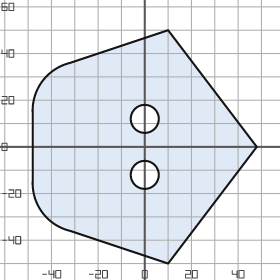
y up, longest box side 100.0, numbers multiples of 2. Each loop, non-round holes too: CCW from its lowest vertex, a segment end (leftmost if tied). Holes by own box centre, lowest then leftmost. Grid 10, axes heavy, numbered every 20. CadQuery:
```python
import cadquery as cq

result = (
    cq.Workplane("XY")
    .moveTo(10.0, -50.0)
    .lineTo(48.0, 0.0)
    .lineTo(10.0, 50.0)
    .lineTo(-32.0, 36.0)
    .threePointArc((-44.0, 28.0), (-48.0, 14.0))
    .lineTo(-48.0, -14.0)
    .threePointArc((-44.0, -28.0), (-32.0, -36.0))
    .close()
    .moveTo(0.0, -12.0)
    .circle(6.0)
    .moveTo(0.0, 12.0)
    .circle(6.0)
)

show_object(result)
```